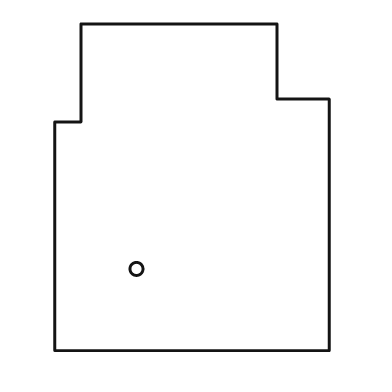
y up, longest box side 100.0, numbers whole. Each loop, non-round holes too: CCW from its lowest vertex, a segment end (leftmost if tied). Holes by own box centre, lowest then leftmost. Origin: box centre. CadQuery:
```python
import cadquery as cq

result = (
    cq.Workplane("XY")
    .moveTo(-42.0, -50.0)
    .lineTo(42.0, -50.0)
    .lineTo(42.0, 27.0)
    .lineTo(26.0, 27.0)
    .lineTo(26.0, 50.0)
    .lineTo(-34.0, 50.0)
    .lineTo(-34.0, 20.0)
    .lineTo(-42.0, 20.0)
    .close()
    .moveTo(-17.0, -25.0)
    .circle(2.0)
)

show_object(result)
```